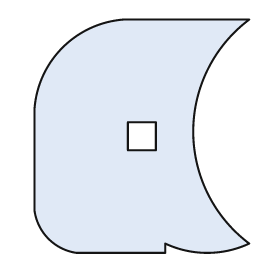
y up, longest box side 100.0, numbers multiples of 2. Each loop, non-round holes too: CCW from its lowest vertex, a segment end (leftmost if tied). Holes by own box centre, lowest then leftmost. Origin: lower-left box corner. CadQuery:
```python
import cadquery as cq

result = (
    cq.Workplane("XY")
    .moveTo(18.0, 0.0)
    .lineTo(56.0, 0.0)
    .lineTo(56.0, 4.0)
    .threePointArc((74.0, 0.0), (92.0, 4.0))
    .threePointArc((68.0, 52.0), (92.0, 100.0))
    .lineTo(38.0, 100.0)
    .threePointArc((12.0, 88.0), (0.0, 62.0))
    .lineTo(0.0, 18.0)
    .threePointArc((6.0, 6.0), (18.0, 0.0))
    .close()
    .moveTo(40.0, 44.0)
    .lineTo(52.0, 44.0)
    .lineTo(52.0, 56.0)
    .lineTo(40.0, 56.0)
    .close()
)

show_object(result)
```